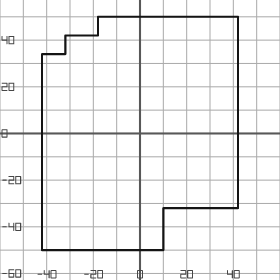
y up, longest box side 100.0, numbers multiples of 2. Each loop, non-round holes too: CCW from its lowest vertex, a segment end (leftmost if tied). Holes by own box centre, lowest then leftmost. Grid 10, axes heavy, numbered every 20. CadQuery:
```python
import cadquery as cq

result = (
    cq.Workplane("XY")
    .moveTo(-42.0, -50.0)
    .lineTo(10.0, -50.0)
    .lineTo(10.0, -32.0)
    .lineTo(42.0, -32.0)
    .lineTo(42.0, 50.0)
    .lineTo(-18.0, 50.0)
    .lineTo(-18.0, 42.0)
    .lineTo(-32.0, 42.0)
    .lineTo(-32.0, 34.0)
    .lineTo(-42.0, 34.0)
    .close()
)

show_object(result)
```